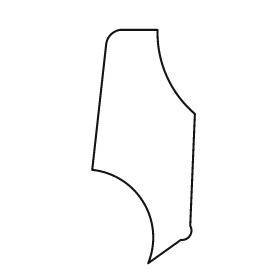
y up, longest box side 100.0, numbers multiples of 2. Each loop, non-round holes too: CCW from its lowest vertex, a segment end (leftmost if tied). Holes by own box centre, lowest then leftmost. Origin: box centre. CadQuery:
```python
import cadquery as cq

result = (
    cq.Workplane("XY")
    .moveTo(2.0, -50.0)
    .lineTo(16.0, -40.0)
    .threePointArc((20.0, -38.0), (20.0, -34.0))
    .lineTo(22.0, 14.0)
    .threePointArc((10.0, 30.0), (6.0, 50.0))
    .lineTo(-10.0, 50.0)
    .threePointArc((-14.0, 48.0), (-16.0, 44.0))
    .lineTo(-22.0, -10.0)
    .threePointArc((0.0, -24.0), (2.0, -50.0))
    .close()
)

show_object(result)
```